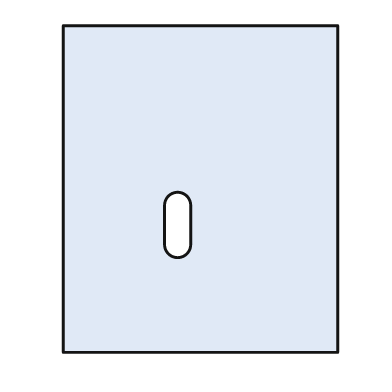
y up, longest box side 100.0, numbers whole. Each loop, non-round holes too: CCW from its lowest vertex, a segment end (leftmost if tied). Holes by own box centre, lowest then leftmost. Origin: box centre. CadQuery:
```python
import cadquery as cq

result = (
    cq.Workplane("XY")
    .moveTo(-42.0, -50.0)
    .lineTo(42.0, -50.0)
    .lineTo(42.0, 50.0)
    .lineTo(-42.0, 50.0)
    .close()
    .moveTo(-11.0, -17.0)
    .threePointArc((-7.0, -21.0), (-3.0, -17.0))
    .lineTo(-3.0, -5.0)
    .threePointArc((-7.0, -1.0), (-11.0, -5.0))
    .close()
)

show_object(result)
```